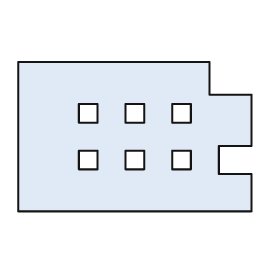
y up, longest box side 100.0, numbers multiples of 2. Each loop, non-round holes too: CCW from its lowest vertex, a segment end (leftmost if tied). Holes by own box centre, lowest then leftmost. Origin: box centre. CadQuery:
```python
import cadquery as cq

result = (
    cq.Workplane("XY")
    .moveTo(-50.0, -32.0)
    .lineTo(50.0, -32.0)
    .lineTo(50.0, -16.0)
    .lineTo(36.0, -16.0)
    .lineTo(36.0, -4.0)
    .lineTo(50.0, -4.0)
    .lineTo(50.0, 18.0)
    .lineTo(32.0, 18.0)
    .lineTo(32.0, 32.0)
    .lineTo(-50.0, 32.0)
    .close()
    .moveTo(-24.0, -14.0)
    .lineTo(-16.0, -14.0)
    .lineTo(-16.0, -6.0)
    .lineTo(-24.0, -6.0)
    .close()
    .moveTo(-4.0, -14.0)
    .lineTo(4.0, -14.0)
    .lineTo(4.0, -6.0)
    .lineTo(-4.0, -6.0)
    .close()
    .moveTo(16.0, -14.0)
    .lineTo(24.0, -14.0)
    .lineTo(24.0, -6.0)
    .lineTo(16.0, -6.0)
    .close()
    .moveTo(-24.0, 6.0)
    .lineTo(-16.0, 6.0)
    .lineTo(-16.0, 14.0)
    .lineTo(-24.0, 14.0)
    .close()
    .moveTo(-4.0, 6.0)
    .lineTo(4.0, 6.0)
    .lineTo(4.0, 14.0)
    .lineTo(-4.0, 14.0)
    .close()
    .moveTo(16.0, 6.0)
    .lineTo(24.0, 6.0)
    .lineTo(24.0, 14.0)
    .lineTo(16.0, 14.0)
    .close()
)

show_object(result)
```